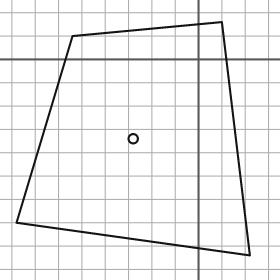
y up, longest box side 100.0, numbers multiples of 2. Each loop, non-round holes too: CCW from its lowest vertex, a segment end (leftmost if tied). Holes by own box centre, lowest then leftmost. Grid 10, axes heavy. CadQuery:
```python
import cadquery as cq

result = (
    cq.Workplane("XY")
    .moveTo(22.0, -84.0)
    .lineTo(10.0, 16.0)
    .lineTo(-54.0, 10.0)
    .lineTo(-78.0, -70.0)
    .close()
    .moveTo(-28.0, -34.0)
    .circle(2.0)
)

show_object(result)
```